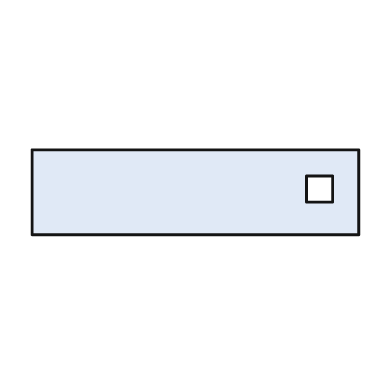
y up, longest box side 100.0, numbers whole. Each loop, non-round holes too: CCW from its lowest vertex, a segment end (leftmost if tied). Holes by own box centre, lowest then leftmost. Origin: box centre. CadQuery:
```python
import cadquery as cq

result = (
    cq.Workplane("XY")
    .moveTo(-50.0, -13.0)
    .lineTo(50.0, -13.0)
    .lineTo(50.0, 13.0)
    .lineTo(-50.0, 13.0)
    .close()
    .moveTo(34.0, -3.0)
    .lineTo(42.0, -3.0)
    .lineTo(42.0, 5.0)
    .lineTo(34.0, 5.0)
    .close()
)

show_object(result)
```